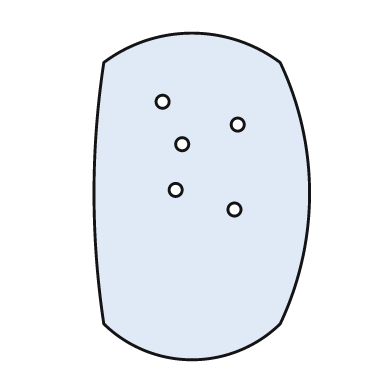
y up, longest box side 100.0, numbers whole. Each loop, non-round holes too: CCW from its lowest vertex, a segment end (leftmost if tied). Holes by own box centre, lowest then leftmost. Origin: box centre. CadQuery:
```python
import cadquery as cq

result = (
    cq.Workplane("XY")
    .moveTo(-30.0, -39.0)
    .threePointArc((-3.0, -50.0), (24.0, -39.0))
    .threePointArc((33.0, 1.0), (24.0, 41.0))
    .threePointArc((-3.0, 50.0), (-30.0, 41.0))
    .threePointArc((-33.0, 1.0), (-30.0, -39.0))
    .close()
    .moveTo(10.0, -4.0)
    .circle(2.0)
    .moveTo(-8.0, 2.0)
    .circle(2.0)
    .moveTo(-6.0, 16.0)
    .circle(2.0)
    .moveTo(11.0, 22.0)
    .circle(2.0)
    .moveTo(-12.0, 29.0)
    .circle(2.0)
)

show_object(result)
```